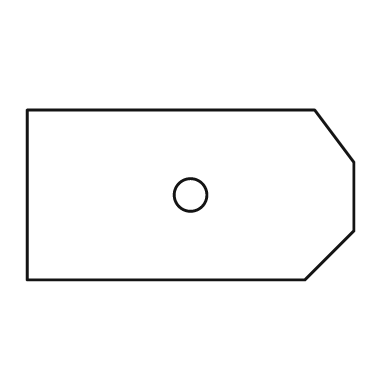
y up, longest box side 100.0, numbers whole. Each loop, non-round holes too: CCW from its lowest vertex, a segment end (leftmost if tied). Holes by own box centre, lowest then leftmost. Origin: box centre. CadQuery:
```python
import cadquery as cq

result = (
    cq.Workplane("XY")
    .moveTo(-50.0, -26.0)
    .lineTo(35.0, -26.0)
    .lineTo(50.0, -11.0)
    .lineTo(50.0, 10.0)
    .lineTo(38.0, 26.0)
    .lineTo(-50.0, 26.0)
    .close()
    .moveTo(0.0, 0.0)
    .circle(5.0)
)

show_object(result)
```